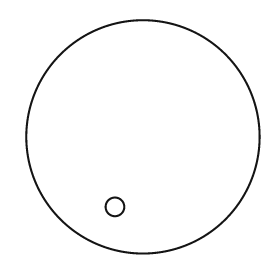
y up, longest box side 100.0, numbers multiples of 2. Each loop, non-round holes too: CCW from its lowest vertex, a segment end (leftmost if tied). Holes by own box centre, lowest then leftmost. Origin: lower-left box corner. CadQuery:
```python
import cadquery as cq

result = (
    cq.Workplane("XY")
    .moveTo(50.0, 50.0)
    .circle(50.0)
    .moveTo(38.0, 20.0)
    .circle(4.0)
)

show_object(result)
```